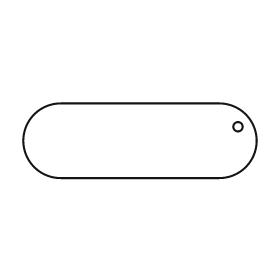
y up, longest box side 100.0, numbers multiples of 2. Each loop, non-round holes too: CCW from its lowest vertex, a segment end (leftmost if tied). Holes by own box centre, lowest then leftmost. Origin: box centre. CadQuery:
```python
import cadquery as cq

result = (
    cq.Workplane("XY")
    .moveTo(-34.0, -16.0)
    .lineTo(34.0, -16.0)
    .threePointArc((50.0, 0.0), (34.0, 16.0))
    .lineTo(-34.0, 16.0)
    .threePointArc((-50.0, 0.0), (-34.0, -16.0))
    .close()
    .moveTo(42.0, 6.0)
    .circle(2.0)
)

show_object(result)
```